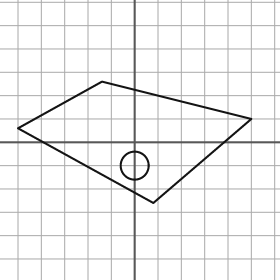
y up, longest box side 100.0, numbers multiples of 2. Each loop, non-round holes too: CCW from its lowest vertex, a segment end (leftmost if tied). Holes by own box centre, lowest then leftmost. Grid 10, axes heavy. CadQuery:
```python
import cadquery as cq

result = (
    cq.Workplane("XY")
    .moveTo(8.0, -26.0)
    .lineTo(50.0, 10.0)
    .lineTo(-14.0, 26.0)
    .lineTo(-50.0, 6.0)
    .close()
    .moveTo(0.0, -10.0)
    .circle(6.0)
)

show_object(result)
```